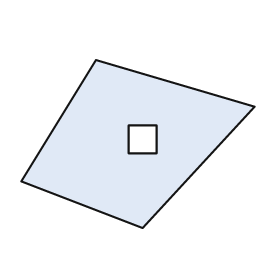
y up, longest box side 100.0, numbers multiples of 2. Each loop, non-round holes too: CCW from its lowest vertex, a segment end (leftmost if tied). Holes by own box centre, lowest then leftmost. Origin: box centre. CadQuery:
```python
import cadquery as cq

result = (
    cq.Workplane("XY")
    .moveTo(2.0, -36.0)
    .lineTo(50.0, 16.0)
    .lineTo(-18.0, 36.0)
    .lineTo(-50.0, -16.0)
    .close()
    .moveTo(-4.0, -4.0)
    .lineTo(8.0, -4.0)
    .lineTo(8.0, 8.0)
    .lineTo(-4.0, 8.0)
    .close()
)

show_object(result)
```